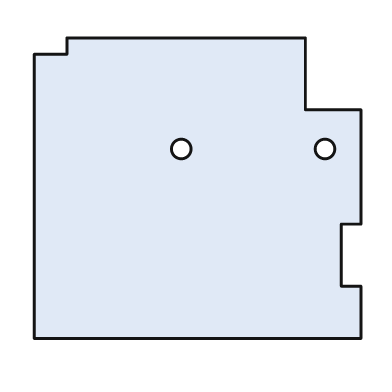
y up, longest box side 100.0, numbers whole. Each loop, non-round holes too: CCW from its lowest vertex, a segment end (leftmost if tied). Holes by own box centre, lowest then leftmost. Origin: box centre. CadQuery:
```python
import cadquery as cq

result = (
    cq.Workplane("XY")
    .moveTo(-50.0, -46.0)
    .lineTo(50.0, -46.0)
    .lineTo(50.0, -30.0)
    .lineTo(44.0, -30.0)
    .lineTo(44.0, -11.0)
    .lineTo(50.0, -11.0)
    .lineTo(50.0, 24.0)
    .lineTo(33.0, 24.0)
    .lineTo(33.0, 46.0)
    .lineTo(-40.0, 46.0)
    .lineTo(-40.0, 41.0)
    .lineTo(-50.0, 41.0)
    .close()
    .moveTo(-5.0, 12.0)
    .circle(3.0)
    .moveTo(39.0, 12.0)
    .circle(3.0)
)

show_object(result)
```